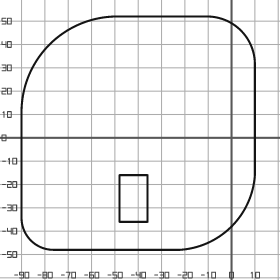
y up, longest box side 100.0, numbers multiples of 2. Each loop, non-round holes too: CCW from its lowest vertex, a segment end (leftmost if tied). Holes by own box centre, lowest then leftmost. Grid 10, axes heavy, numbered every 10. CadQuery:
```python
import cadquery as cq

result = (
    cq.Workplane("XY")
    .moveTo(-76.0, -48.0)
    .lineTo(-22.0, -48.0)
    .threePointArc((0.0, -38.0), (10.0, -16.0))
    .lineTo(10.0, 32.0)
    .threePointArc((4.0, 46.0), (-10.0, 52.0))
    .lineTo(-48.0, 52.0)
    .threePointArc((-78.0, 40.0), (-90.0, 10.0))
    .lineTo(-90.0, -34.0)
    .threePointArc((-86.0, -44.0), (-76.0, -48.0))
    .close()
    .moveTo(-48.0, -36.0)
    .lineTo(-36.0, -36.0)
    .lineTo(-36.0, -16.0)
    .lineTo(-48.0, -16.0)
    .close()
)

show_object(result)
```